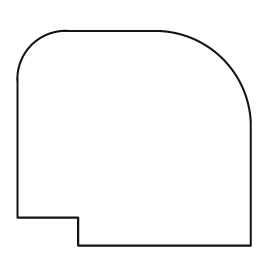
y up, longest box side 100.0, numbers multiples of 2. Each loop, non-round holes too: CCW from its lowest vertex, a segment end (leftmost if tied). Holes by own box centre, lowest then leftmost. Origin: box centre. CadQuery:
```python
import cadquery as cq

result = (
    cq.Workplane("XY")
    .moveTo(-24.0, -46.0)
    .lineTo(50.0, -46.0)
    .lineTo(50.0, 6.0)
    .threePointArc((38.0, 34.0), (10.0, 46.0))
    .lineTo(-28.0, 46.0)
    .threePointArc((-44.0, 40.0), (-50.0, 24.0))
    .lineTo(-50.0, -34.0)
    .lineTo(-24.0, -34.0)
    .close()
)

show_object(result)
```